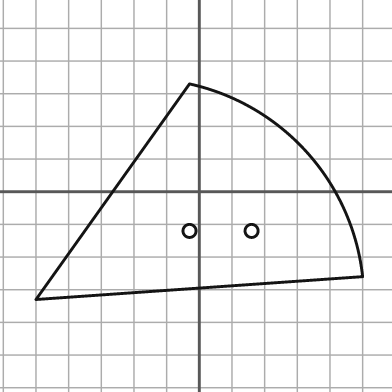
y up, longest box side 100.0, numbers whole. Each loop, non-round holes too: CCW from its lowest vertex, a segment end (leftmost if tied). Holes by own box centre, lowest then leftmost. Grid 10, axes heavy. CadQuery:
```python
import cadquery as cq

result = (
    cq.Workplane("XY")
    .moveTo(-50.0, -33.0)
    .lineTo(50.0, -26.0)
    .threePointArc((33.0, 12.0), (-3.0, 33.0))
    .close()
    .moveTo(-3.0, -12.0)
    .circle(2.0)
    .moveTo(16.0, -12.0)
    .circle(2.0)
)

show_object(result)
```